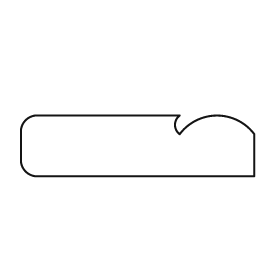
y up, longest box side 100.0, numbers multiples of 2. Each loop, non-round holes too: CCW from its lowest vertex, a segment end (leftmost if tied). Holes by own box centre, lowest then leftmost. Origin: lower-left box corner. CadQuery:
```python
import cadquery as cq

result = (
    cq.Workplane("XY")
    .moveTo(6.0, 0.0)
    .lineTo(100.0, 0.0)
    .lineTo(100.0, 18.0)
    .threePointArc((84.0, 26.0), (68.0, 18.0))
    .threePointArc((66.0, 22.0), (68.0, 26.0))
    .lineTo(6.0, 26.0)
    .threePointArc((2.0, 24.0), (0.0, 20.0))
    .lineTo(0.0, 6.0)
    .threePointArc((2.0, 2.0), (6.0, 0.0))
    .close()
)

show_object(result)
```